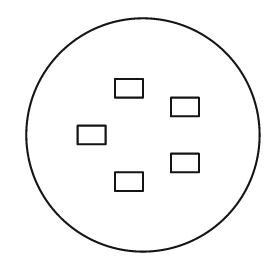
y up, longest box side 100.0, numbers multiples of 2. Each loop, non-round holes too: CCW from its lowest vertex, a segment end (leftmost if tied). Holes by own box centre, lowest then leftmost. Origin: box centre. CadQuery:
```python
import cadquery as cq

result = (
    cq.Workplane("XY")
    .moveTo(0.0, 0.0)
    .circle(50.0)
    .moveTo(-12.0, -24.0)
    .lineTo(0.0, -24.0)
    .lineTo(0.0, -16.0)
    .lineTo(-12.0, -16.0)
    .close()
    .moveTo(12.0, -16.0)
    .lineTo(24.0, -16.0)
    .lineTo(24.0, -8.0)
    .lineTo(12.0, -8.0)
    .close()
    .moveTo(-28.0, -4.0)
    .lineTo(-16.0, -4.0)
    .lineTo(-16.0, 4.0)
    .lineTo(-28.0, 4.0)
    .close()
    .moveTo(12.0, 8.0)
    .lineTo(24.0, 8.0)
    .lineTo(24.0, 16.0)
    .lineTo(12.0, 16.0)
    .close()
    .moveTo(-12.0, 16.0)
    .lineTo(0.0, 16.0)
    .lineTo(0.0, 24.0)
    .lineTo(-12.0, 24.0)
    .close()
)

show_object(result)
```